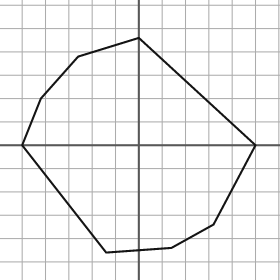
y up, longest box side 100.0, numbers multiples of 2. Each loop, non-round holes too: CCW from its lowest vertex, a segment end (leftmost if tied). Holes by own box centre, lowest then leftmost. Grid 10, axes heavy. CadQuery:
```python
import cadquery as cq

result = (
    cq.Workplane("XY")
    .moveTo(-14.0, -46.0)
    .lineTo(14.0, -44.0)
    .lineTo(32.0, -34.0)
    .lineTo(50.0, 0.0)
    .lineTo(0.0, 46.0)
    .lineTo(-26.0, 38.0)
    .lineTo(-42.0, 20.0)
    .lineTo(-50.0, 0.0)
    .close()
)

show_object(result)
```